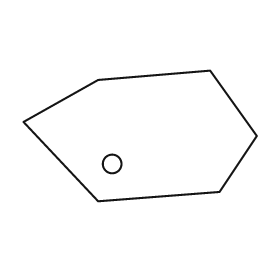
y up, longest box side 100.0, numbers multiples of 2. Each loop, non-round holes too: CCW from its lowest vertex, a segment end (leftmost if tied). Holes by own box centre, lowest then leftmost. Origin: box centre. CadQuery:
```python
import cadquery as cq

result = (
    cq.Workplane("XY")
    .moveTo(-18.0, -28.0)
    .lineTo(34.0, -24.0)
    .lineTo(50.0, 0.0)
    .lineTo(30.0, 28.0)
    .lineTo(-18.0, 24.0)
    .lineTo(-50.0, 6.0)
    .close()
    .moveTo(-12.0, -12.0)
    .circle(4.0)
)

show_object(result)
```